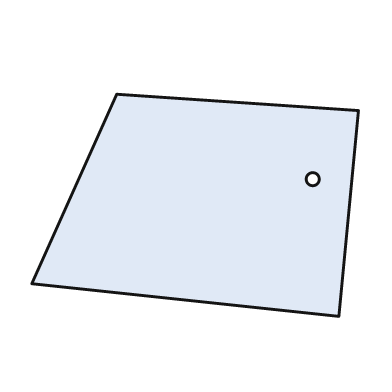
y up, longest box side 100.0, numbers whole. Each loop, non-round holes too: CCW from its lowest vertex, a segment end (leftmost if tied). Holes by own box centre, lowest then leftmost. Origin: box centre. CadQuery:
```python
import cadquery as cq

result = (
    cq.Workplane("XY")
    .moveTo(44.0, -34.0)
    .lineTo(50.0, 29.0)
    .lineTo(-24.0, 34.0)
    .lineTo(-50.0, -24.0)
    .close()
    .moveTo(36.0, 8.0)
    .circle(2.0)
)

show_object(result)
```